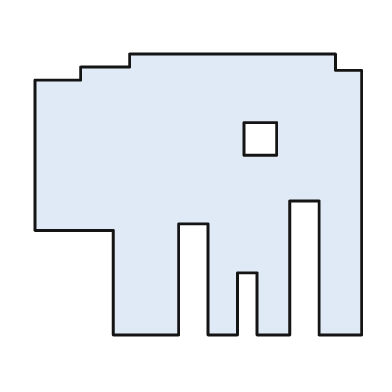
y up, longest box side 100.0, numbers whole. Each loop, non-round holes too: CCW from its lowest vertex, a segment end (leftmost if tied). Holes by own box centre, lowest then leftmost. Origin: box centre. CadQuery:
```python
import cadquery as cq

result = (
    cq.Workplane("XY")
    .moveTo(-26.0, -43.0)
    .lineTo(-6.0, -43.0)
    .lineTo(-6.0, -9.0)
    .lineTo(3.0, -9.0)
    .lineTo(3.0, -43.0)
    .lineTo(12.0, -43.0)
    .lineTo(12.0, -24.0)
    .lineTo(18.0, -24.0)
    .lineTo(18.0, -43.0)
    .lineTo(28.0, -43.0)
    .lineTo(28.0, -2.0)
    .lineTo(37.0, -2.0)
    .lineTo(37.0, -43.0)
    .lineTo(50.0, -43.0)
    .lineTo(50.0, 38.0)
    .lineTo(42.0, 38.0)
    .lineTo(42.0, 43.0)
    .lineTo(-21.0, 43.0)
    .lineTo(-21.0, 39.0)
    .lineTo(-36.0, 39.0)
    .lineTo(-36.0, 35.0)
    .lineTo(-50.0, 35.0)
    .lineTo(-50.0, -11.0)
    .lineTo(-26.0, -11.0)
    .close()
    .moveTo(14.0, 12.0)
    .lineTo(24.0, 12.0)
    .lineTo(24.0, 22.0)
    .lineTo(14.0, 22.0)
    .close()
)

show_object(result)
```